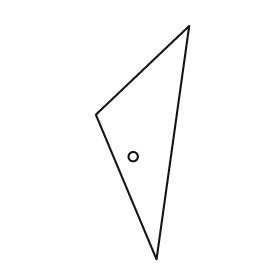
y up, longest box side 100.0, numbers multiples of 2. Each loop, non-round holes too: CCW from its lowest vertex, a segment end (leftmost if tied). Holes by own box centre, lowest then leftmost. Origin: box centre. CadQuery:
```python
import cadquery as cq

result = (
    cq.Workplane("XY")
    .moveTo(6.0, -50.0)
    .lineTo(20.0, 50.0)
    .lineTo(-20.0, 12.0)
    .close()
    .moveTo(-4.0, -6.0)
    .circle(2.0)
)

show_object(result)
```